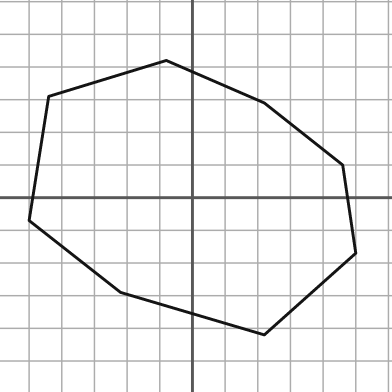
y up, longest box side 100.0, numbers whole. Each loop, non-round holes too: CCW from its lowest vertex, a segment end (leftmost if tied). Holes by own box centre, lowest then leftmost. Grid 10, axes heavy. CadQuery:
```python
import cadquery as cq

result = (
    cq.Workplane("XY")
    .moveTo(22.0, -42.0)
    .lineTo(50.0, -17.0)
    .lineTo(46.0, 10.0)
    .lineTo(22.0, 29.0)
    .lineTo(-8.0, 42.0)
    .lineTo(-44.0, 31.0)
    .lineTo(-50.0, -7.0)
    .lineTo(-22.0, -29.0)
    .close()
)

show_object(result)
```